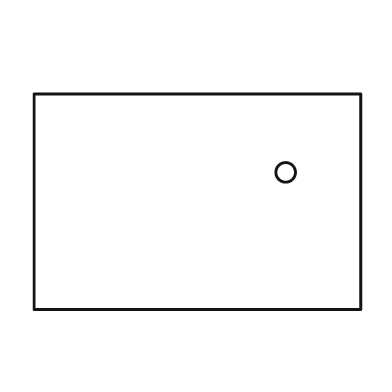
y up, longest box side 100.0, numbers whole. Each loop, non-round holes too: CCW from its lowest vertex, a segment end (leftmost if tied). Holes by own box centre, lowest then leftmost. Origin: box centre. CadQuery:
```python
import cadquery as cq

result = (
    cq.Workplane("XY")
    .moveTo(-50.0, -33.0)
    .lineTo(50.0, -33.0)
    .lineTo(50.0, 33.0)
    .lineTo(-50.0, 33.0)
    .close()
    .moveTo(27.0, 9.0)
    .circle(3.0)
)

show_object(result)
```